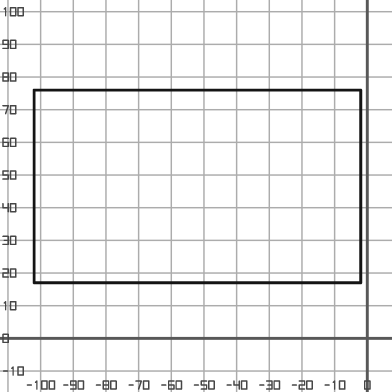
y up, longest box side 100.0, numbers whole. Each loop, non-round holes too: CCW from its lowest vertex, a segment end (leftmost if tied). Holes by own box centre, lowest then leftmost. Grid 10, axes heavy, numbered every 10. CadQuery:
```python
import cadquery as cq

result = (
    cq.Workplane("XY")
    .moveTo(-102.0, 17.0)
    .lineTo(-2.0, 17.0)
    .lineTo(-2.0, 76.0)
    .lineTo(-102.0, 76.0)
    .close()
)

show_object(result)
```